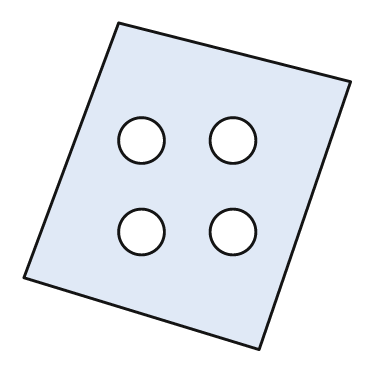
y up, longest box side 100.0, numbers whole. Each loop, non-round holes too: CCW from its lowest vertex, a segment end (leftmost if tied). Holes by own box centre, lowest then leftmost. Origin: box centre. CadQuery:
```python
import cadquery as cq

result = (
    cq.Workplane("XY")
    .moveTo(22.0, -50.0)
    .lineTo(50.0, 32.0)
    .lineTo(-21.0, 50.0)
    .lineTo(-50.0, -28.0)
    .close()
    .moveTo(-14.0, -14.0)
    .circle(7.0)
    .moveTo(14.0, -14.0)
    .circle(7.0)
    .moveTo(-14.0, 14.0)
    .circle(7.0)
    .moveTo(14.0, 14.0)
    .circle(7.0)
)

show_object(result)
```